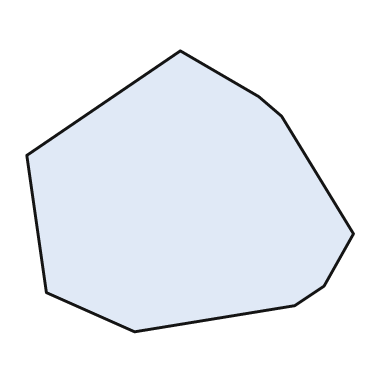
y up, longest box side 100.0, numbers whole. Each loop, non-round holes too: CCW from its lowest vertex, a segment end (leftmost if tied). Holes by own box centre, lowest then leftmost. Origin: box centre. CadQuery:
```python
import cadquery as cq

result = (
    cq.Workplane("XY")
    .moveTo(-17.0, -43.0)
    .lineTo(32.0, -35.0)
    .lineTo(41.0, -29.0)
    .lineTo(50.0, -13.0)
    .lineTo(28.0, 23.0)
    .lineTo(21.0, 29.0)
    .lineTo(-3.0, 43.0)
    .lineTo(-50.0, 11.0)
    .lineTo(-44.0, -31.0)
    .close()
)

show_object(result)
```